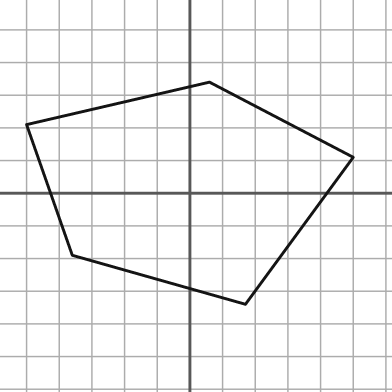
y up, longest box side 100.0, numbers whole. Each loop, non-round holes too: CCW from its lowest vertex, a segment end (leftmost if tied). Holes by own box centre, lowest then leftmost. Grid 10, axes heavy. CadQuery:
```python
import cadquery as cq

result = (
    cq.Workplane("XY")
    .moveTo(17.0, -34.0)
    .lineTo(50.0, 11.0)
    .lineTo(6.0, 34.0)
    .lineTo(-50.0, 21.0)
    .lineTo(-36.0, -19.0)
    .close()
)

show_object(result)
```